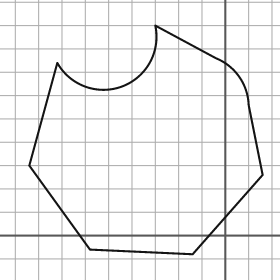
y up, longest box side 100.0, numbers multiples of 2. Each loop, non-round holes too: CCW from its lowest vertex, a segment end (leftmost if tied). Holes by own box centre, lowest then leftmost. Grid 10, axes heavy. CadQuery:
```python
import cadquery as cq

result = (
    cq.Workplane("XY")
    .moveTo(-14.0, -8.0)
    .lineTo(16.0, 26.0)
    .lineTo(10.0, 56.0)
    .threePointArc((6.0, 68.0), (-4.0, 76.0))
    .lineTo(-30.0, 90.0)
    .threePointArc((-44.0, 64.0), (-72.0, 74.0))
    .lineTo(-84.0, 30.0)
    .lineTo(-58.0, -6.0)
    .close()
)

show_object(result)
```